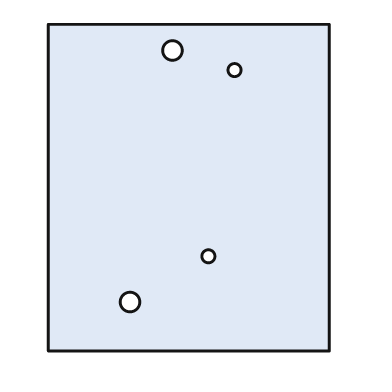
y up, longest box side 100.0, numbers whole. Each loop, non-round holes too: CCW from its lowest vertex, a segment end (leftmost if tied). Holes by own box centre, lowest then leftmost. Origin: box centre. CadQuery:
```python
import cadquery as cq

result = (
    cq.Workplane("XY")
    .moveTo(-43.0, -50.0)
    .lineTo(43.0, -50.0)
    .lineTo(43.0, 50.0)
    .lineTo(-43.0, 50.0)
    .close()
    .moveTo(-18.0, -35.0)
    .circle(3.0)
    .moveTo(6.0, -21.0)
    .circle(2.0)
    .moveTo(14.0, 36.0)
    .circle(2.0)
    .moveTo(-5.0, 42.0)
    .circle(3.0)
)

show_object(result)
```